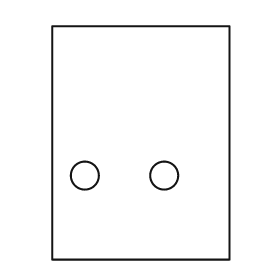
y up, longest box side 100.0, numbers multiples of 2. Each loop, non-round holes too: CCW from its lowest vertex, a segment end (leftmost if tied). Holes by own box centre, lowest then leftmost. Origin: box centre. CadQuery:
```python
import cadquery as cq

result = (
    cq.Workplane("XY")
    .moveTo(-38.0, -50.0)
    .lineTo(38.0, -50.0)
    .lineTo(38.0, 50.0)
    .lineTo(-38.0, 50.0)
    .close()
    .moveTo(-24.0, -14.0)
    .circle(6.0)
    .moveTo(10.0, -14.0)
    .circle(6.0)
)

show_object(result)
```